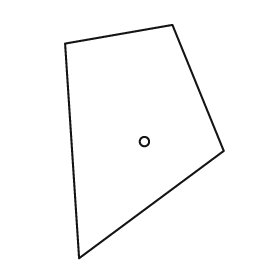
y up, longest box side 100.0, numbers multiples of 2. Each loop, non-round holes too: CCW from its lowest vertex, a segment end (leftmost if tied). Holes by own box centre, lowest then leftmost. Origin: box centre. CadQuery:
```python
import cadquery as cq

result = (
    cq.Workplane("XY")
    .moveTo(-28.0, -50.0)
    .lineTo(34.0, -4.0)
    .lineTo(12.0, 50.0)
    .lineTo(-34.0, 42.0)
    .close()
    .moveTo(0.0, 0.0)
    .circle(2.0)
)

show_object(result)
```